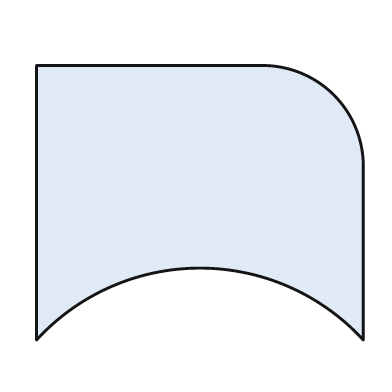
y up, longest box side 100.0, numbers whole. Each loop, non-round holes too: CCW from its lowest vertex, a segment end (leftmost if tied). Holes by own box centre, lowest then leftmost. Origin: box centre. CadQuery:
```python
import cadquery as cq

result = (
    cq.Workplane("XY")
    .moveTo(-50.0, -42.0)
    .threePointArc((0.0, -20.0), (50.0, -42.0))
    .lineTo(50.0, 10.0)
    .threePointArc((41.0, 33.0), (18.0, 42.0))
    .lineTo(-50.0, 42.0)
    .close()
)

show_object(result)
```